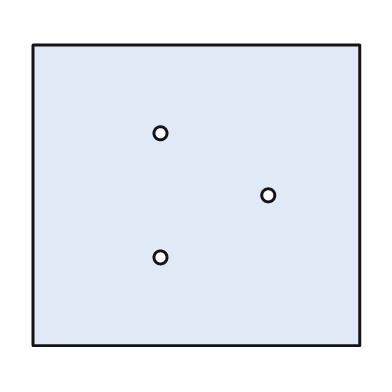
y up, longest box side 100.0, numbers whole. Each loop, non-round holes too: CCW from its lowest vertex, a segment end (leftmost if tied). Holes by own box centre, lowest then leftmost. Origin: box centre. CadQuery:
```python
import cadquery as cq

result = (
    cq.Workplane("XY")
    .moveTo(-50.0, -46.0)
    .lineTo(50.0, -46.0)
    .lineTo(50.0, 46.0)
    .lineTo(-50.0, 46.0)
    .close()
    .moveTo(-11.0, -19.0)
    .circle(2.0)
    .moveTo(22.0, 0.0)
    .circle(2.0)
    .moveTo(-11.0, 19.0)
    .circle(2.0)
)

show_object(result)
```